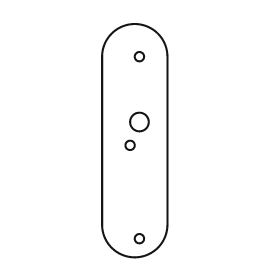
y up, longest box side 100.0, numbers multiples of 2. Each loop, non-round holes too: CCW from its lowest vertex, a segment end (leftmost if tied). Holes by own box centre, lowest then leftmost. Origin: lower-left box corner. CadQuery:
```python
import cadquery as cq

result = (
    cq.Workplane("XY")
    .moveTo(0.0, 14.0)
    .threePointArc((14.0, 0.0), (28.0, 14.0))
    .lineTo(28.0, 86.0)
    .threePointArc((14.0, 100.0), (0.0, 86.0))
    .close()
    .moveTo(16.0, 8.0)
    .circle(2.0)
    .moveTo(12.0, 48.0)
    .circle(2.0)
    .moveTo(16.0, 58.0)
    .circle(4.0)
    .moveTo(16.0, 86.0)
    .circle(2.0)
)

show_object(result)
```